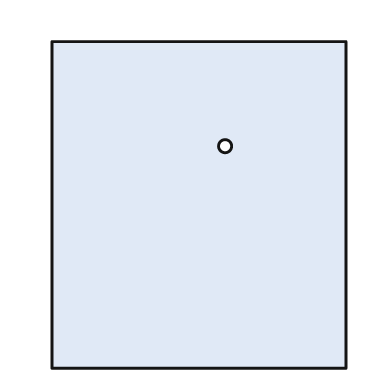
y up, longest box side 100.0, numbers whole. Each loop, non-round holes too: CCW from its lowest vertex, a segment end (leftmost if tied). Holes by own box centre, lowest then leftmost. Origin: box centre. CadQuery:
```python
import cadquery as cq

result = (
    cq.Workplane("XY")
    .moveTo(-45.0, -50.0)
    .lineTo(45.0, -50.0)
    .lineTo(45.0, 50.0)
    .lineTo(-45.0, 50.0)
    .close()
    .moveTo(8.0, 18.0)
    .circle(2.0)
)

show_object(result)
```